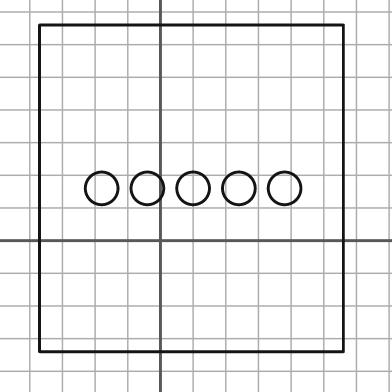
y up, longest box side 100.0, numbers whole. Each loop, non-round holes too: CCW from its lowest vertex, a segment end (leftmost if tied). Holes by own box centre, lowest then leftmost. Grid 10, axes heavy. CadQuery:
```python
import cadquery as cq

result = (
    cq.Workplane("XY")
    .moveTo(-37.0, -34.0)
    .lineTo(56.0, -34.0)
    .lineTo(56.0, 66.0)
    .lineTo(-37.0, 66.0)
    .close()
    .moveTo(-18.0, 16.0)
    .circle(5.0)
    .moveTo(-4.0, 16.0)
    .circle(5.0)
    .moveTo(10.0, 16.0)
    .circle(5.0)
    .moveTo(24.0, 16.0)
    .circle(5.0)
    .moveTo(38.0, 16.0)
    .circle(5.0)
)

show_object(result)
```